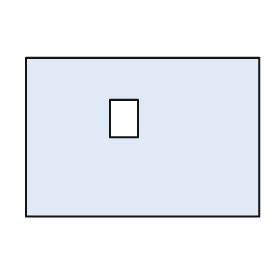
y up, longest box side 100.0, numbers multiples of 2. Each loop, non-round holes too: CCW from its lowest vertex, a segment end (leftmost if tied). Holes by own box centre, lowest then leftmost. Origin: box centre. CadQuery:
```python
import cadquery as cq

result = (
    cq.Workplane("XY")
    .moveTo(-50.0, -34.0)
    .lineTo(50.0, -34.0)
    .lineTo(50.0, 34.0)
    .lineTo(-50.0, 34.0)
    .close()
    .moveTo(-14.0, 0.0)
    .lineTo(-2.0, 0.0)
    .lineTo(-2.0, 16.0)
    .lineTo(-14.0, 16.0)
    .close()
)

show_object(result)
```